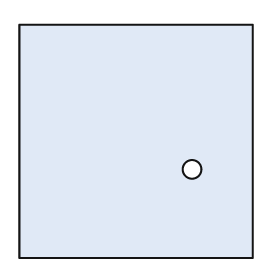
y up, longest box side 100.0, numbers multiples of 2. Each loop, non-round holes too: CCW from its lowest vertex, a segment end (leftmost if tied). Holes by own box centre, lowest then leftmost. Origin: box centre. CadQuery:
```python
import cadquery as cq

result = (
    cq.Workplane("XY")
    .moveTo(-50.0, -50.0)
    .lineTo(50.0, -50.0)
    .lineTo(50.0, 50.0)
    .lineTo(-50.0, 50.0)
    .close()
    .moveTo(24.0, -12.0)
    .circle(4.0)
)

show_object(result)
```